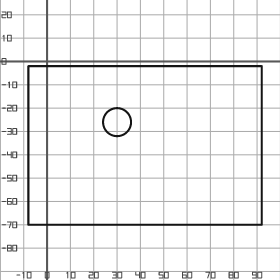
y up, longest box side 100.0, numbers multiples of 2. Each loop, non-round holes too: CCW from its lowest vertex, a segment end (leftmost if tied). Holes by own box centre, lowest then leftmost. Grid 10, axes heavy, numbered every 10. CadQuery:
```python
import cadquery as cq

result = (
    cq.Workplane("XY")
    .moveTo(-8.0, -70.0)
    .lineTo(92.0, -70.0)
    .lineTo(92.0, -2.0)
    .lineTo(-8.0, -2.0)
    .close()
    .moveTo(30.0, -26.0)
    .circle(6.0)
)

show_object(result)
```